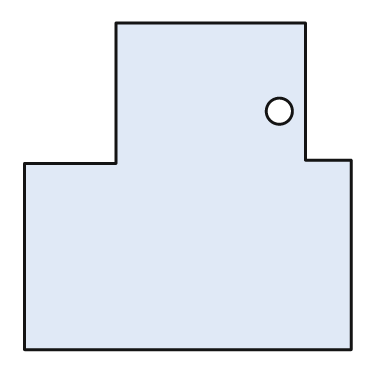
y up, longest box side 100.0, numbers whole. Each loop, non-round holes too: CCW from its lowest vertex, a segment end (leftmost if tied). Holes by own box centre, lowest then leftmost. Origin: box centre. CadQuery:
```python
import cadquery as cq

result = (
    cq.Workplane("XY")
    .moveTo(-50.0, -50.0)
    .lineTo(50.0, -50.0)
    .lineTo(50.0, 8.0)
    .lineTo(36.0, 8.0)
    .lineTo(36.0, 50.0)
    .lineTo(-22.0, 50.0)
    .lineTo(-22.0, 7.0)
    .lineTo(-50.0, 7.0)
    .close()
    .moveTo(28.0, 23.0)
    .circle(4.0)
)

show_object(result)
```